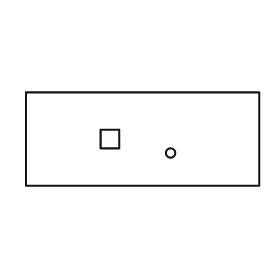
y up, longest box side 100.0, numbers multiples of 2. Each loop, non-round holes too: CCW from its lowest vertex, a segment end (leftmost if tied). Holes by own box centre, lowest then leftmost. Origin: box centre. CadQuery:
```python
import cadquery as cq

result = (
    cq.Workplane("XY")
    .moveTo(-50.0, -20.0)
    .lineTo(50.0, -20.0)
    .lineTo(50.0, 20.0)
    .lineTo(-50.0, 20.0)
    .close()
    .moveTo(12.0, -6.0)
    .circle(2.0)
    .moveTo(-18.0, -4.0)
    .lineTo(-10.0, -4.0)
    .lineTo(-10.0, 4.0)
    .lineTo(-18.0, 4.0)
    .close()
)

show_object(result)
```